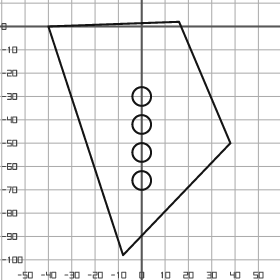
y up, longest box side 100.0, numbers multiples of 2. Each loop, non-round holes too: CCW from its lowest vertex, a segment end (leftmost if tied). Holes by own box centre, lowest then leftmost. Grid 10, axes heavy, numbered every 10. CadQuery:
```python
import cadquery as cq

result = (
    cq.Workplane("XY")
    .moveTo(-8.0, -98.0)
    .lineTo(38.0, -50.0)
    .lineTo(16.0, 2.0)
    .lineTo(-40.0, 0.0)
    .close()
    .moveTo(0.0, -66.0)
    .circle(4.0)
    .moveTo(0.0, -54.0)
    .circle(4.0)
    .moveTo(0.0, -42.0)
    .circle(4.0)
    .moveTo(0.0, -30.0)
    .circle(4.0)
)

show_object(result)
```